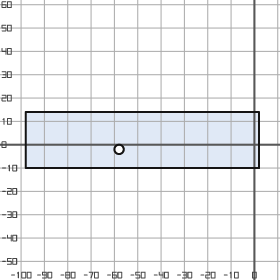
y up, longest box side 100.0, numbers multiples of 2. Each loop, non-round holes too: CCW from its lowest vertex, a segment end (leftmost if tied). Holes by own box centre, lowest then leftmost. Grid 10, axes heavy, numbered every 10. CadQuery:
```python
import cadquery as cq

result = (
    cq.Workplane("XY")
    .moveTo(-98.0, -10.0)
    .lineTo(2.0, -10.0)
    .lineTo(2.0, 14.0)
    .lineTo(-98.0, 14.0)
    .close()
    .moveTo(-58.0, -2.0)
    .circle(2.0)
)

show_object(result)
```